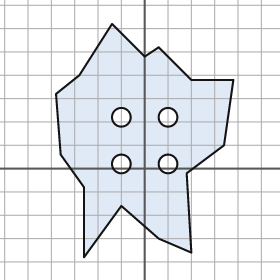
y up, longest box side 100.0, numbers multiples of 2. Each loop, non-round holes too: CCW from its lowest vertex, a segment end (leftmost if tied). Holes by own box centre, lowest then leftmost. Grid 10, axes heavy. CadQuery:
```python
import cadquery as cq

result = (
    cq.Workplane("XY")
    .moveTo(-26.0, -38.0)
    .lineTo(-10.0, -16.0)
    .lineTo(6.0, -30.0)
    .lineTo(20.0, -36.0)
    .lineTo(18.0, -2.0)
    .lineTo(34.0, 10.0)
    .lineTo(38.0, 38.0)
    .lineTo(20.0, 38.0)
    .lineTo(6.0, 52.0)
    .lineTo(0.0, 48.0)
    .lineTo(-14.0, 62.0)
    .lineTo(-28.0, 40.0)
    .lineTo(-38.0, 32.0)
    .lineTo(-36.0, 6.0)
    .lineTo(-26.0, -8.0)
    .close()
    .moveTo(-10.0, 2.0)
    .circle(4.0)
    .moveTo(10.0, 2.0)
    .circle(4.0)
    .moveTo(-10.0, 22.0)
    .circle(4.0)
    .moveTo(10.0, 22.0)
    .circle(4.0)
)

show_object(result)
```